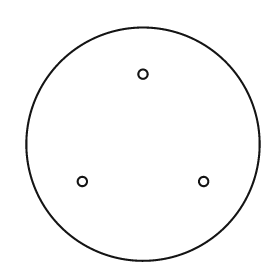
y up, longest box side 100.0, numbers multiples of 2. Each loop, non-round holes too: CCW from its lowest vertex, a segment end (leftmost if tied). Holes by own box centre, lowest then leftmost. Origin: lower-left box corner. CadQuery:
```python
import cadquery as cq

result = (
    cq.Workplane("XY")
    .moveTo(50.0, 50.0)
    .circle(50.0)
    .moveTo(24.0, 34.0)
    .circle(2.0)
    .moveTo(76.0, 34.0)
    .circle(2.0)
    .moveTo(50.0, 80.0)
    .circle(2.0)
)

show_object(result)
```